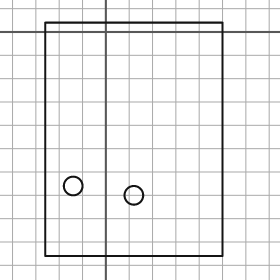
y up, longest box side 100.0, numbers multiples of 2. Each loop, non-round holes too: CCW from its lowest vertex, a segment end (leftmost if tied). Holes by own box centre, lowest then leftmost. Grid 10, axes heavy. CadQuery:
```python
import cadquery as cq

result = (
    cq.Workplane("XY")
    .moveTo(-26.0, -96.0)
    .lineTo(50.0, -96.0)
    .lineTo(50.0, 4.0)
    .lineTo(-26.0, 4.0)
    .close()
    .moveTo(12.0, -70.0)
    .circle(4.0)
    .moveTo(-14.0, -66.0)
    .circle(4.0)
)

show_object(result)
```